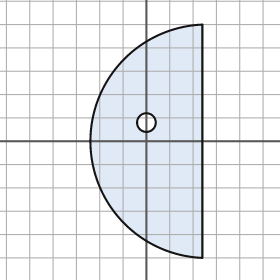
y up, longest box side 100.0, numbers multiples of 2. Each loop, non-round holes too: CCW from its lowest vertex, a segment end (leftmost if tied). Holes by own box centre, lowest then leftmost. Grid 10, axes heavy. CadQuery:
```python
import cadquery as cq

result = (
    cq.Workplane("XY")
    .moveTo(24.0, -50.0)
    .lineTo(24.0, 50.0)
    .threePointArc((-24.0, 0.0), (24.0, -50.0))
    .close()
    .moveTo(0.0, 8.0)
    .circle(4.0)
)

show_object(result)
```